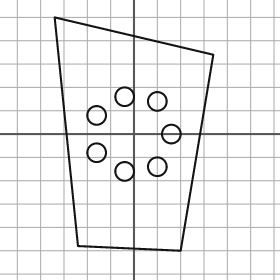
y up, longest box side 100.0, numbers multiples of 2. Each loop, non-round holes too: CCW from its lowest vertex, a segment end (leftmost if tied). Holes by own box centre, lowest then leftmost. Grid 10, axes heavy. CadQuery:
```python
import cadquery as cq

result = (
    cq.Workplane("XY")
    .moveTo(20.0, -50.0)
    .lineTo(34.0, 34.0)
    .lineTo(-34.0, 50.0)
    .lineTo(-24.0, -48.0)
    .close()
    .moveTo(-4.0, -16.0)
    .circle(4.0)
    .moveTo(10.0, -14.0)
    .circle(4.0)
    .moveTo(-16.0, -8.0)
    .circle(4.0)
    .moveTo(16.0, 0.0)
    .circle(4.0)
    .moveTo(-16.0, 8.0)
    .circle(4.0)
    .moveTo(10.0, 14.0)
    .circle(4.0)
    .moveTo(-4.0, 16.0)
    .circle(4.0)
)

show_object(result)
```